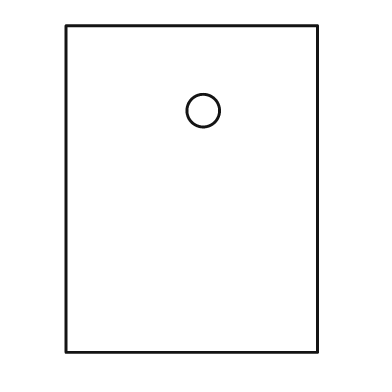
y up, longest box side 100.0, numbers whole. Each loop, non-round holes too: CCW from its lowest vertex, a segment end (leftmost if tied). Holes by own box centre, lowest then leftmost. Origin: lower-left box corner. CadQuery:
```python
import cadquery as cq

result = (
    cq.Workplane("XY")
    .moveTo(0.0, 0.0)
    .lineTo(77.0, 0.0)
    .lineTo(77.0, 100.0)
    .lineTo(0.0, 100.0)
    .close()
    .moveTo(42.0, 74.0)
    .circle(5.0)
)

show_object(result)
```